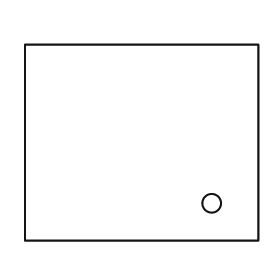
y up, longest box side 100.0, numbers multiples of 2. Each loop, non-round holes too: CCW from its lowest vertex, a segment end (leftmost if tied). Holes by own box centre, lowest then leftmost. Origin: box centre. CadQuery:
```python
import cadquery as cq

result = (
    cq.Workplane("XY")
    .moveTo(-50.0, -42.0)
    .lineTo(50.0, -42.0)
    .lineTo(50.0, 42.0)
    .lineTo(-50.0, 42.0)
    .close()
    .moveTo(30.0, -26.0)
    .circle(4.0)
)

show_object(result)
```